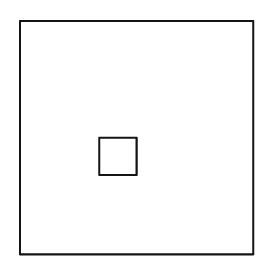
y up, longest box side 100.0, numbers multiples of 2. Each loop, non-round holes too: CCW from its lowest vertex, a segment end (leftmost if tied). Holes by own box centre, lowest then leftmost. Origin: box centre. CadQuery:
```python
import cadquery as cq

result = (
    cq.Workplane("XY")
    .moveTo(-50.0, -50.0)
    .lineTo(50.0, -50.0)
    .lineTo(50.0, 50.0)
    .lineTo(-50.0, 50.0)
    .close()
    .moveTo(-16.0, -16.0)
    .lineTo(0.0, -16.0)
    .lineTo(0.0, 0.0)
    .lineTo(-16.0, 0.0)
    .close()
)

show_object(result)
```